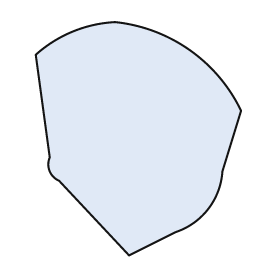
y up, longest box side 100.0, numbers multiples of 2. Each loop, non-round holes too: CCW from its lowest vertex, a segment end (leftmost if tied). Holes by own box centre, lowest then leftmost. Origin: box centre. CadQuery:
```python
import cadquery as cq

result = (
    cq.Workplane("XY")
    .moveTo(-4.0, -50.0)
    .lineTo(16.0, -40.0)
    .threePointArc((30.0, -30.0), (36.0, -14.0))
    .lineTo(44.0, 12.0)
    .threePointArc((22.0, 38.0), (-10.0, 50.0))
    .threePointArc((-28.0, 46.0), (-44.0, 36.0))
    .lineTo(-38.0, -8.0)
    .threePointArc((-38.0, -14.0), (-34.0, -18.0))
    .close()
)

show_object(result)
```